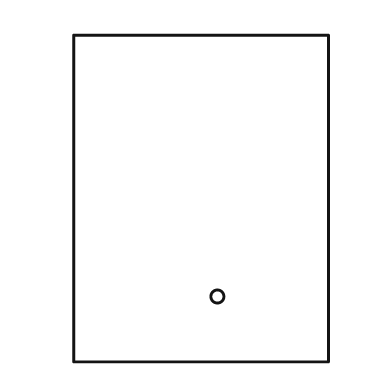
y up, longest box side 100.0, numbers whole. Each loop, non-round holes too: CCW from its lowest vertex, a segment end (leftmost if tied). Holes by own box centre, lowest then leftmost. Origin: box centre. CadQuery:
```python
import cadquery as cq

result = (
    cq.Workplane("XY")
    .moveTo(-39.0, -50.0)
    .lineTo(39.0, -50.0)
    .lineTo(39.0, 50.0)
    .lineTo(-39.0, 50.0)
    .close()
    .moveTo(5.0, -30.0)
    .circle(2.0)
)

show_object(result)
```